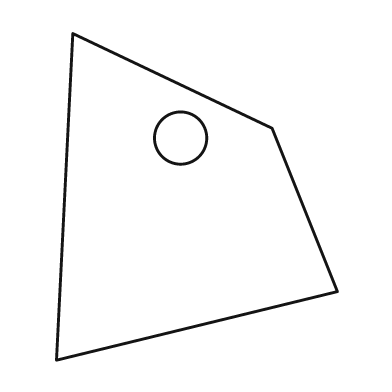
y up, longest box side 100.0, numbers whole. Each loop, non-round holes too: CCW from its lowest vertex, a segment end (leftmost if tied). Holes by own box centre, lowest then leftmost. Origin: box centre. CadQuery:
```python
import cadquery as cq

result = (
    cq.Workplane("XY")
    .moveTo(-43.0, -50.0)
    .lineTo(43.0, -29.0)
    .lineTo(23.0, 21.0)
    .lineTo(-38.0, 50.0)
    .close()
    .moveTo(-5.0, 18.0)
    .circle(8.0)
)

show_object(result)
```